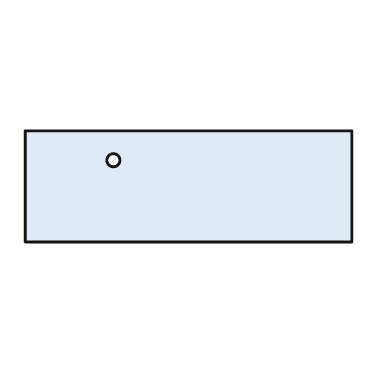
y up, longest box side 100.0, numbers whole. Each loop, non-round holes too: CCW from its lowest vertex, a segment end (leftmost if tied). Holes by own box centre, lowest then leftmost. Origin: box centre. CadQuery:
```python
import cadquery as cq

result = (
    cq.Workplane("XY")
    .moveTo(-50.0, -17.0)
    .lineTo(50.0, -17.0)
    .lineTo(50.0, 17.0)
    .lineTo(-50.0, 17.0)
    .close()
    .moveTo(-23.0, 8.0)
    .circle(2.0)
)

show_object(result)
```